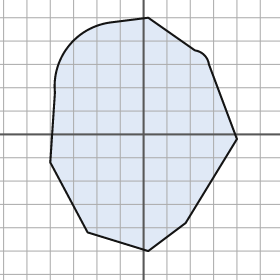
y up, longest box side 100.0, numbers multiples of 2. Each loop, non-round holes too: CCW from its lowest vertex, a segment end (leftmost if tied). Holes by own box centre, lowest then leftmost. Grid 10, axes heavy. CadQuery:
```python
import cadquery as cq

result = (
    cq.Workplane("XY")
    .moveTo(2.0, -50.0)
    .lineTo(18.0, -38.0)
    .lineTo(40.0, -2.0)
    .lineTo(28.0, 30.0)
    .threePointArc((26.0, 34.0), (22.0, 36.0))
    .lineTo(2.0, 50.0)
    .lineTo(-14.0, 48.0)
    .threePointArc((-32.0, 38.0), (-38.0, 18.0))
    .lineTo(-40.0, -12.0)
    .lineTo(-24.0, -42.0)
    .close()
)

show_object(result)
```